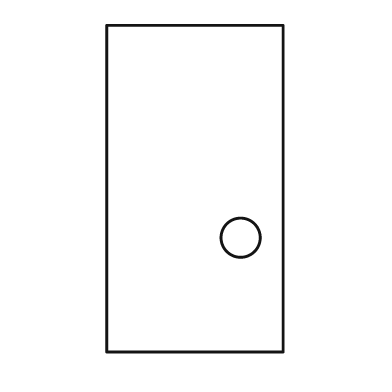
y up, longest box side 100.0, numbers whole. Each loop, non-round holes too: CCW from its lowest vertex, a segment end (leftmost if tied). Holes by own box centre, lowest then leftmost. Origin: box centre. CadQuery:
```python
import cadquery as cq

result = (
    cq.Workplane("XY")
    .moveTo(-27.0, -50.0)
    .lineTo(27.0, -50.0)
    .lineTo(27.0, 50.0)
    .lineTo(-27.0, 50.0)
    .close()
    .moveTo(14.0, -15.0)
    .circle(6.0)
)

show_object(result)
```